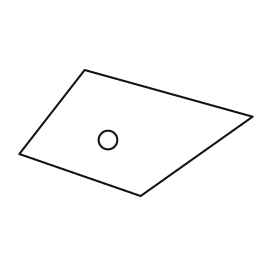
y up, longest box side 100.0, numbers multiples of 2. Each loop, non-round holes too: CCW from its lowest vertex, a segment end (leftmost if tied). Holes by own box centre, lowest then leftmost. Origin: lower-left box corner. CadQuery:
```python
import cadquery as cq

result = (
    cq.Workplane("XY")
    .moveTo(52.0, 0.0)
    .lineTo(100.0, 34.0)
    .lineTo(28.0, 54.0)
    .lineTo(0.0, 18.0)
    .close()
    .moveTo(38.0, 24.0)
    .circle(4.0)
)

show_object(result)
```